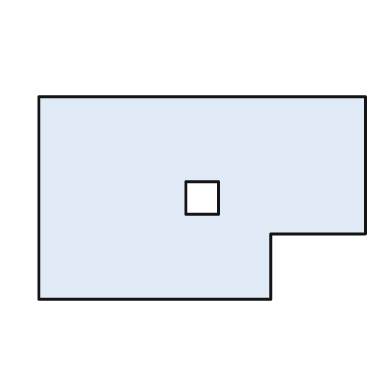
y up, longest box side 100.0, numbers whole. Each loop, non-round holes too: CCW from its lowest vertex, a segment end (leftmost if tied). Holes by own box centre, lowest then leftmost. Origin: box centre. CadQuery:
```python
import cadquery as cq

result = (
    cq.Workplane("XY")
    .moveTo(-50.0, -31.0)
    .lineTo(21.0, -31.0)
    .lineTo(21.0, -11.0)
    .lineTo(50.0, -11.0)
    .lineTo(50.0, 31.0)
    .lineTo(-50.0, 31.0)
    .close()
    .moveTo(-5.0, -5.0)
    .lineTo(5.0, -5.0)
    .lineTo(5.0, 5.0)
    .lineTo(-5.0, 5.0)
    .close()
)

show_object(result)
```